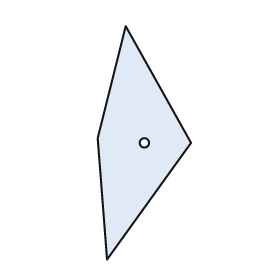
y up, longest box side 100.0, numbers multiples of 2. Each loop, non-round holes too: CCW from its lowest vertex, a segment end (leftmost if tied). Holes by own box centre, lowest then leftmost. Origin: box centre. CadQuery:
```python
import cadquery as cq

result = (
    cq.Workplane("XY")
    .moveTo(-16.0, -50.0)
    .lineTo(20.0, 0.0)
    .lineTo(-8.0, 50.0)
    .lineTo(-20.0, 2.0)
    .close()
    .moveTo(0.0, 0.0)
    .circle(2.0)
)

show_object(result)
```